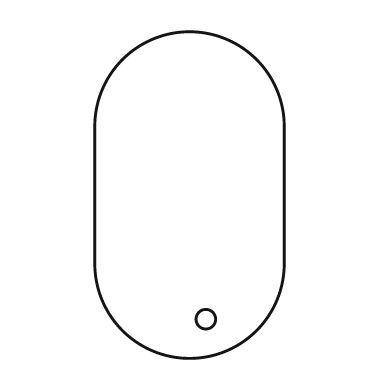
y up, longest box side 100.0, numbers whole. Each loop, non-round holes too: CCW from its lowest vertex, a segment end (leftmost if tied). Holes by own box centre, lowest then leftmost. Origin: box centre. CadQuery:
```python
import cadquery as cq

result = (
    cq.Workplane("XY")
    .moveTo(-29.0, -21.0)
    .threePointArc((0.0, -50.0), (29.0, -21.0))
    .lineTo(29.0, 21.0)
    .threePointArc((0.0, 50.0), (-29.0, 21.0))
    .close()
    .moveTo(5.0, -38.0)
    .circle(3.0)
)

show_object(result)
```